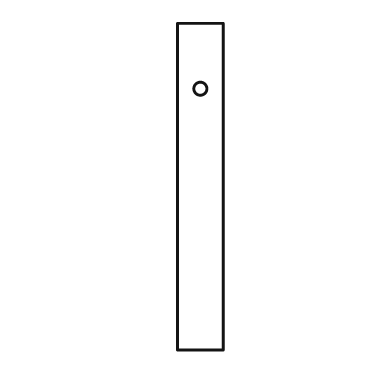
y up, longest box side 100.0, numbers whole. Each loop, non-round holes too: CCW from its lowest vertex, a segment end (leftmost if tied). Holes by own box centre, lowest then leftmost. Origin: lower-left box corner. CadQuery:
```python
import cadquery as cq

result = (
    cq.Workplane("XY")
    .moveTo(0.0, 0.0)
    .lineTo(14.0, 0.0)
    .lineTo(14.0, 100.0)
    .lineTo(0.0, 100.0)
    .close()
    .moveTo(7.0, 80.0)
    .circle(2.0)
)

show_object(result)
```